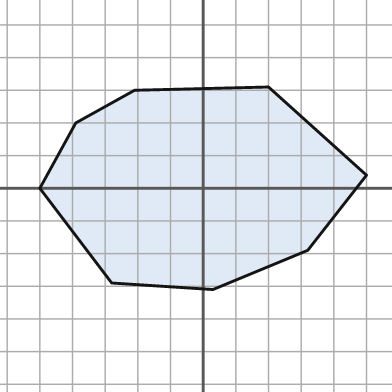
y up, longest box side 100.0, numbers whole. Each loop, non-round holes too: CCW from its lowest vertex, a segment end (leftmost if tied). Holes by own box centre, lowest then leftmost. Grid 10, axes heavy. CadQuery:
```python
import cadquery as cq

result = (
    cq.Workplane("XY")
    .moveTo(3.0, -31.0)
    .lineTo(32.0, -19.0)
    .lineTo(50.0, 4.0)
    .lineTo(20.0, 31.0)
    .lineTo(-21.0, 30.0)
    .lineTo(-39.0, 20.0)
    .lineTo(-50.0, 0.0)
    .lineTo(-28.0, -29.0)
    .close()
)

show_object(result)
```